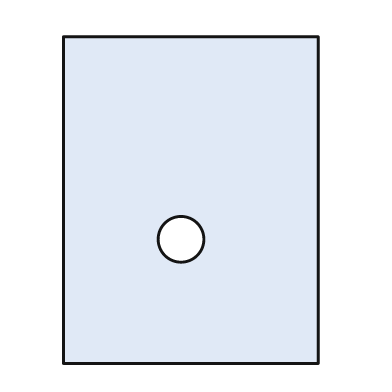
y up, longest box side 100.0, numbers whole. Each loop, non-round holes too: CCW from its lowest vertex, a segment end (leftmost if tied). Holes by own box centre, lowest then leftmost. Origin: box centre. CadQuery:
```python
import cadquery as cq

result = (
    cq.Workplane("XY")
    .moveTo(-39.0, -50.0)
    .lineTo(39.0, -50.0)
    .lineTo(39.0, 50.0)
    .lineTo(-39.0, 50.0)
    .close()
    .moveTo(-3.0, -12.0)
    .circle(7.0)
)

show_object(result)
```